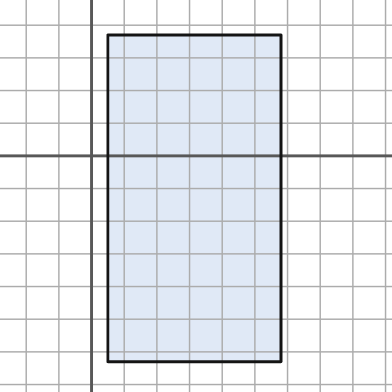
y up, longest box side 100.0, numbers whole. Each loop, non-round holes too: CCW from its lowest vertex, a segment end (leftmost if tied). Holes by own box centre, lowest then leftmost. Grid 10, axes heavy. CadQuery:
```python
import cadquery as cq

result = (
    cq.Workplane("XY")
    .moveTo(5.0, -63.0)
    .lineTo(58.0, -63.0)
    .lineTo(58.0, 37.0)
    .lineTo(5.0, 37.0)
    .close()
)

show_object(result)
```